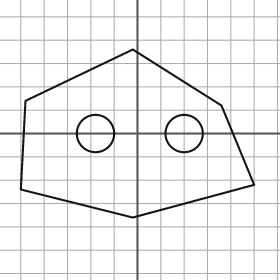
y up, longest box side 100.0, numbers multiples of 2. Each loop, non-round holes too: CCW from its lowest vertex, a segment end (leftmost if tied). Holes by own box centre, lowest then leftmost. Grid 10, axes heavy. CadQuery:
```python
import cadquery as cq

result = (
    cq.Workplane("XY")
    .moveTo(-2.0, -36.0)
    .lineTo(50.0, -22.0)
    .lineTo(36.0, 12.0)
    .lineTo(-2.0, 36.0)
    .lineTo(-48.0, 14.0)
    .lineTo(-50.0, -24.0)
    .close()
    .moveTo(-18.0, 0.0)
    .circle(8.0)
    .moveTo(20.0, 0.0)
    .circle(8.0)
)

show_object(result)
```